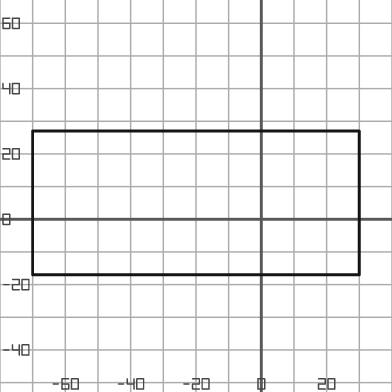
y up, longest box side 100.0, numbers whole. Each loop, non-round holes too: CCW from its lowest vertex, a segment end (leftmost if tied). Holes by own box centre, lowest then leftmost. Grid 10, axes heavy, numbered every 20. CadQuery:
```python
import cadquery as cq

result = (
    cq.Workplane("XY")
    .moveTo(-70.0, -17.0)
    .lineTo(30.0, -17.0)
    .lineTo(30.0, 27.0)
    .lineTo(-70.0, 27.0)
    .close()
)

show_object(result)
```